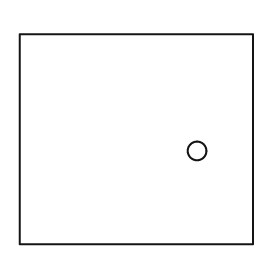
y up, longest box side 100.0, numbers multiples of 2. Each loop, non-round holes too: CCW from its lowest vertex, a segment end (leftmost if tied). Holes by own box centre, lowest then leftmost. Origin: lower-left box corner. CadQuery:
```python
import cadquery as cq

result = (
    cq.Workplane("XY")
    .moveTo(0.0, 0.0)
    .lineTo(100.0, 0.0)
    .lineTo(100.0, 90.0)
    .lineTo(0.0, 90.0)
    .close()
    .moveTo(76.0, 40.0)
    .circle(4.0)
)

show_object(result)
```